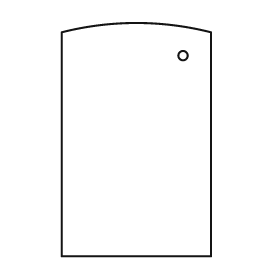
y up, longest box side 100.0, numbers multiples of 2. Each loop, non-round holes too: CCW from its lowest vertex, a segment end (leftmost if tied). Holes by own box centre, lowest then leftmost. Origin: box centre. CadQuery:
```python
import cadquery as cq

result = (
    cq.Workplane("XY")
    .moveTo(-32.0, -50.0)
    .lineTo(32.0, -50.0)
    .lineTo(32.0, 46.0)
    .threePointArc((0.0, 50.0), (-32.0, 46.0))
    .close()
    .moveTo(20.0, 36.0)
    .circle(2.0)
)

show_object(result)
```